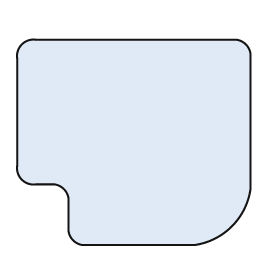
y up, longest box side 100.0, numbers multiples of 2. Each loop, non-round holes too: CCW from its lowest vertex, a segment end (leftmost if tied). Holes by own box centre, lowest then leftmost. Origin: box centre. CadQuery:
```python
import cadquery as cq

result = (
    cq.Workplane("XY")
    .moveTo(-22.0, -44.0)
    .lineTo(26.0, -44.0)
    .threePointArc((42.0, -36.0), (50.0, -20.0))
    .lineTo(50.0, 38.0)
    .threePointArc((48.0, 42.0), (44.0, 44.0))
    .lineTo(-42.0, 44.0)
    .threePointArc((-48.0, 42.0), (-50.0, 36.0))
    .lineTo(-50.0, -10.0)
    .threePointArc((-48.0, -16.0), (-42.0, -18.0))
    .lineTo(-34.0, -18.0)
    .threePointArc((-30.0, -20.0), (-28.0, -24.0))
    .lineTo(-28.0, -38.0)
    .threePointArc((-26.0, -42.0), (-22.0, -44.0))
    .close()
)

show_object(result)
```